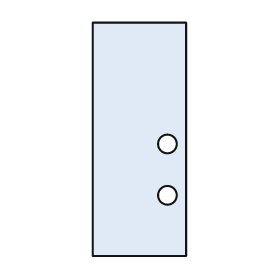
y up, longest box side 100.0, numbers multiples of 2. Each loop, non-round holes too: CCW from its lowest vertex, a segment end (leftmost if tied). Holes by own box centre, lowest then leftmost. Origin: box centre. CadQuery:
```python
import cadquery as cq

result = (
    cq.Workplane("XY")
    .moveTo(-20.0, -50.0)
    .lineTo(20.0, -50.0)
    .lineTo(20.0, 50.0)
    .lineTo(-20.0, 50.0)
    .close()
    .moveTo(12.0, -24.0)
    .circle(4.0)
    .moveTo(12.0, -2.0)
    .circle(4.0)
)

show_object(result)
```